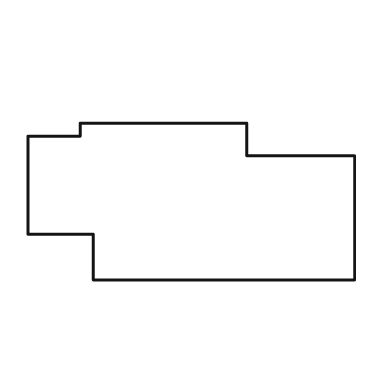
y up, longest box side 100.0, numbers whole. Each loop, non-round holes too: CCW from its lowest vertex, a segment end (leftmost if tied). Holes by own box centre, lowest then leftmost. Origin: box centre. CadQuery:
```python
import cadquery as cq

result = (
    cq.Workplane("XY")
    .moveTo(-30.0, -24.0)
    .lineTo(50.0, -24.0)
    .lineTo(50.0, 14.0)
    .lineTo(17.0, 14.0)
    .lineTo(17.0, 24.0)
    .lineTo(-34.0, 24.0)
    .lineTo(-34.0, 20.0)
    .lineTo(-50.0, 20.0)
    .lineTo(-50.0, -10.0)
    .lineTo(-30.0, -10.0)
    .close()
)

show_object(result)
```